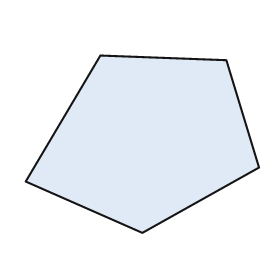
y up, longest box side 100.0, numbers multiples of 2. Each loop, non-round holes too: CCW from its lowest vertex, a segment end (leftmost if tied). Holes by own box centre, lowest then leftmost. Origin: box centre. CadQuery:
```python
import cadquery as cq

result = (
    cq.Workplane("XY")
    .moveTo(0.0, -38.0)
    .lineTo(50.0, -10.0)
    .lineTo(36.0, 36.0)
    .lineTo(-18.0, 38.0)
    .lineTo(-50.0, -16.0)
    .close()
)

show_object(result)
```